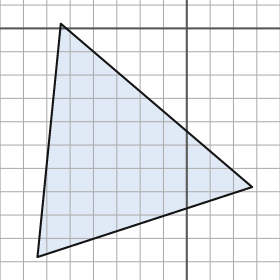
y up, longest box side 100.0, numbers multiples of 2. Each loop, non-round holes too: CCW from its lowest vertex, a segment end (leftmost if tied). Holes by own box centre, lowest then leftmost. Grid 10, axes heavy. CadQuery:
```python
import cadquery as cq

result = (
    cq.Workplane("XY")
    .moveTo(-64.0, -98.0)
    .lineTo(28.0, -68.0)
    .lineTo(-54.0, 2.0)
    .close()
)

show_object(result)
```